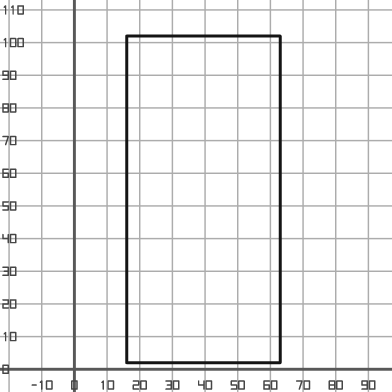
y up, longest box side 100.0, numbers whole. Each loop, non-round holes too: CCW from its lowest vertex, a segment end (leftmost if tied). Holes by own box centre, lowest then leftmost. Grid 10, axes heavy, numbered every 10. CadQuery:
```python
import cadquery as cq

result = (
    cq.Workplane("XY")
    .moveTo(16.0, 2.0)
    .lineTo(63.0, 2.0)
    .lineTo(63.0, 102.0)
    .lineTo(16.0, 102.0)
    .close()
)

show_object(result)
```